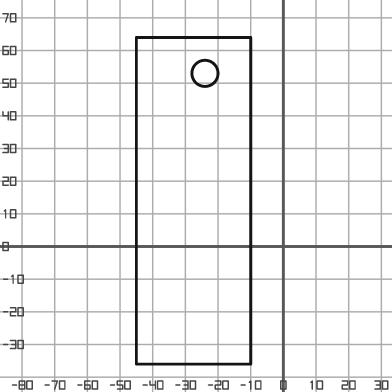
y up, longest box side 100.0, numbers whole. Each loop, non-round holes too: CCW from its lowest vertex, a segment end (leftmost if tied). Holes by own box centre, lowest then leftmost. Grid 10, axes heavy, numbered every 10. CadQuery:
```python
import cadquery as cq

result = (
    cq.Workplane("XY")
    .moveTo(-45.0, -36.0)
    .lineTo(-10.0, -36.0)
    .lineTo(-10.0, 64.0)
    .lineTo(-45.0, 64.0)
    .close()
    .moveTo(-24.0, 53.0)
    .circle(4.0)
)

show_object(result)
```